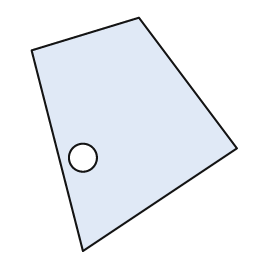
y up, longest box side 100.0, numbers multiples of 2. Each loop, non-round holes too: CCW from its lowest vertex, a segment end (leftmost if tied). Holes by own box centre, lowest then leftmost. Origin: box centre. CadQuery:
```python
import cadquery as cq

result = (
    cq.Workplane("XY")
    .moveTo(-22.0, -50.0)
    .lineTo(44.0, -6.0)
    .lineTo(2.0, 50.0)
    .lineTo(-44.0, 36.0)
    .close()
    .moveTo(-22.0, -10.0)
    .circle(6.0)
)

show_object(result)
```